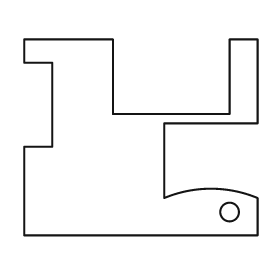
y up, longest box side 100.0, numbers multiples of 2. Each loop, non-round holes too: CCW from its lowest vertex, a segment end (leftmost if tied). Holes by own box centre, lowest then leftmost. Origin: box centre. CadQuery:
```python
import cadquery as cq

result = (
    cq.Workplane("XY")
    .moveTo(-50.0, -42.0)
    .lineTo(50.0, -42.0)
    .lineTo(50.0, -26.0)
    .threePointArc((30.0, -22.0), (10.0, -26.0))
    .lineTo(10.0, 6.0)
    .lineTo(50.0, 6.0)
    .lineTo(50.0, 42.0)
    .lineTo(38.0, 42.0)
    .lineTo(38.0, 10.0)
    .lineTo(-12.0, 10.0)
    .lineTo(-12.0, 42.0)
    .lineTo(-50.0, 42.0)
    .lineTo(-50.0, 32.0)
    .lineTo(-38.0, 32.0)
    .lineTo(-38.0, -4.0)
    .lineTo(-50.0, -4.0)
    .close()
    .moveTo(38.0, -32.0)
    .circle(4.0)
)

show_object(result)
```